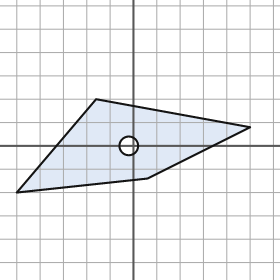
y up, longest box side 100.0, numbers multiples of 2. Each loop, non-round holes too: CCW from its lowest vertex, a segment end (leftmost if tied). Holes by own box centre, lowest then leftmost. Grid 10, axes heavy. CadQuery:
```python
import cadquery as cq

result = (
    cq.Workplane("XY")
    .moveTo(-50.0, -20.0)
    .lineTo(6.0, -14.0)
    .lineTo(50.0, 8.0)
    .lineTo(-16.0, 20.0)
    .close()
    .moveTo(-2.0, 0.0)
    .circle(4.0)
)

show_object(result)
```